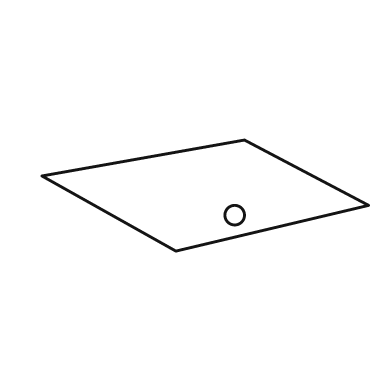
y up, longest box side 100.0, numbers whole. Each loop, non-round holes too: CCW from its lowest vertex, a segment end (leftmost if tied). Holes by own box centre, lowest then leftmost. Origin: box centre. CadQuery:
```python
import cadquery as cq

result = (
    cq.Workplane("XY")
    .moveTo(-9.0, -17.0)
    .lineTo(50.0, -3.0)
    .lineTo(12.0, 17.0)
    .lineTo(-50.0, 6.0)
    .close()
    .moveTo(9.0, -6.0)
    .circle(3.0)
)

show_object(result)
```